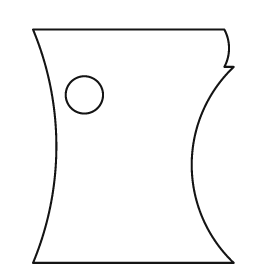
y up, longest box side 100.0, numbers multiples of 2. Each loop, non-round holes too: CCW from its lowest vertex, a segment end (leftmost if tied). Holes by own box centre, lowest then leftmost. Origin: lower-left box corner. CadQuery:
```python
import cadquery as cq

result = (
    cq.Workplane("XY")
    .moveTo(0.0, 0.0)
    .lineTo(86.0, 0.0)
    .threePointArc((68.0, 42.0), (86.0, 84.0))
    .lineTo(82.0, 84.0)
    .threePointArc((84.0, 92.0), (82.0, 100.0))
    .lineTo(0.0, 100.0)
    .threePointArc((10.0, 50.0), (0.0, 0.0))
    .close()
    .moveTo(22.0, 72.0)
    .circle(8.0)
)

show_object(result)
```